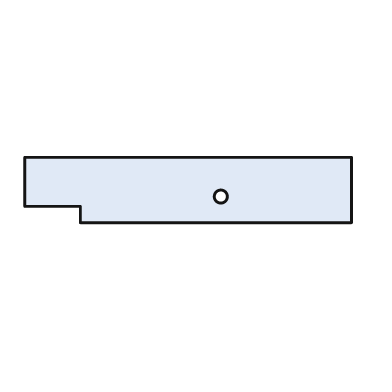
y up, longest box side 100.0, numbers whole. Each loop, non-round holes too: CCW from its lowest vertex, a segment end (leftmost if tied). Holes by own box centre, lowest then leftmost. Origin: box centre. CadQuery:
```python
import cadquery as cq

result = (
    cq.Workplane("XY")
    .moveTo(-33.0, -10.0)
    .lineTo(50.0, -10.0)
    .lineTo(50.0, 10.0)
    .lineTo(-50.0, 10.0)
    .lineTo(-50.0, -5.0)
    .lineTo(-33.0, -5.0)
    .close()
    .moveTo(10.0, -2.0)
    .circle(2.0)
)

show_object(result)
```